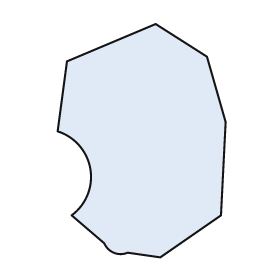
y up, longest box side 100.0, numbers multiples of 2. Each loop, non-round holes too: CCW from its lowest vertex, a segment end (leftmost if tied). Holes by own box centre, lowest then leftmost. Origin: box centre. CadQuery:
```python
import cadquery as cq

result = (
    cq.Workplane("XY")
    .moveTo(8.0, -50.0)
    .lineTo(34.0, -32.0)
    .lineTo(36.0, 8.0)
    .lineTo(28.0, 36.0)
    .lineTo(6.0, 50.0)
    .lineTo(-32.0, 34.0)
    .lineTo(-36.0, 4.0)
    .threePointArc((-22.0, -12.0), (-30.0, -32.0))
    .lineTo(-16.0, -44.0)
    .threePointArc((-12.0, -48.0), (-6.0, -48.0))
    .close()
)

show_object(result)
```